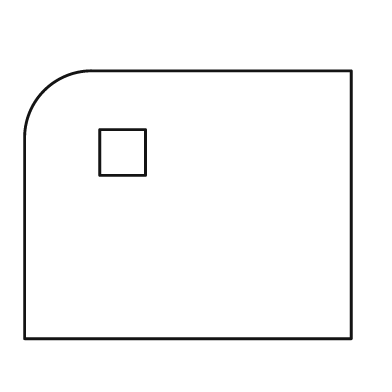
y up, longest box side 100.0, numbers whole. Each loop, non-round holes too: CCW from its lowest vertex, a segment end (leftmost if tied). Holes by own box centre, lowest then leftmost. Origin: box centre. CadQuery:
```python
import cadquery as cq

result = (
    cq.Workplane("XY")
    .moveTo(-50.0, -41.0)
    .lineTo(50.0, -41.0)
    .lineTo(50.0, 41.0)
    .lineTo(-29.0, 41.0)
    .threePointArc((-44.0, 35.0), (-50.0, 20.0))
    .close()
    .moveTo(-27.0, 9.0)
    .lineTo(-13.0, 9.0)
    .lineTo(-13.0, 23.0)
    .lineTo(-27.0, 23.0)
    .close()
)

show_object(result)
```